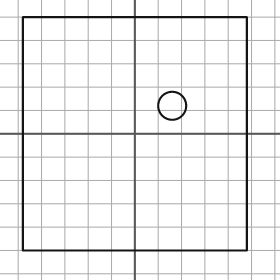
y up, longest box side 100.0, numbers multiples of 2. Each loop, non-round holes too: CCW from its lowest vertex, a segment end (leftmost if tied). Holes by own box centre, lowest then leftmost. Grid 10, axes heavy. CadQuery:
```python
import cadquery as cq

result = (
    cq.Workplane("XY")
    .moveTo(-48.0, -50.0)
    .lineTo(48.0, -50.0)
    .lineTo(48.0, 50.0)
    .lineTo(-48.0, 50.0)
    .close()
    .moveTo(16.0, 12.0)
    .circle(6.0)
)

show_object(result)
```